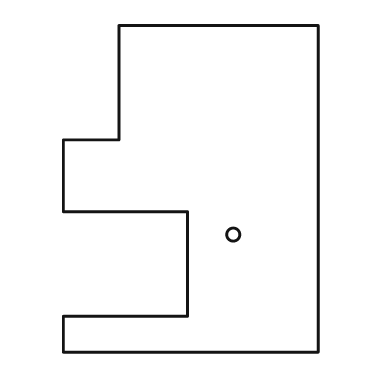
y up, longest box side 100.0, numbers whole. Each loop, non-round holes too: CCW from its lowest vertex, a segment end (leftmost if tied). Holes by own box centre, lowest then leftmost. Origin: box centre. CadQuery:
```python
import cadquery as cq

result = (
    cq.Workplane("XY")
    .moveTo(-39.0, -50.0)
    .lineTo(39.0, -50.0)
    .lineTo(39.0, 50.0)
    .lineTo(-22.0, 50.0)
    .lineTo(-22.0, 15.0)
    .lineTo(-39.0, 15.0)
    .lineTo(-39.0, -7.0)
    .lineTo(-1.0, -7.0)
    .lineTo(-1.0, -39.0)
    .lineTo(-39.0, -39.0)
    .close()
    .moveTo(13.0, -14.0)
    .circle(2.0)
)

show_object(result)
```